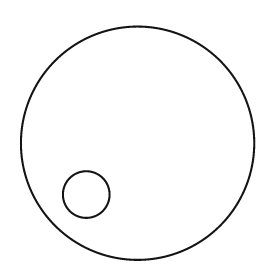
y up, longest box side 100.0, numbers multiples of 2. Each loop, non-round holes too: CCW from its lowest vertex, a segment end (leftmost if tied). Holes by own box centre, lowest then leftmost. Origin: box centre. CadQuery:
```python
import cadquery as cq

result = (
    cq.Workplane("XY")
    .moveTo(0.0, 0.0)
    .circle(50.0)
    .moveTo(-22.0, -22.0)
    .circle(10.0)
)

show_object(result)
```